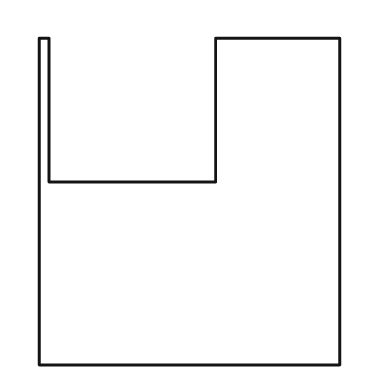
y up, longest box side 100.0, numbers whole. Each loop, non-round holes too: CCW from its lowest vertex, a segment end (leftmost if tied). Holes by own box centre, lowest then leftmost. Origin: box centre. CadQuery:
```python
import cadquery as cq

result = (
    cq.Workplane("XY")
    .moveTo(-46.0, -50.0)
    .lineTo(46.0, -50.0)
    .lineTo(46.0, 50.0)
    .lineTo(8.0, 50.0)
    .lineTo(8.0, 6.0)
    .lineTo(-43.0, 6.0)
    .lineTo(-43.0, 50.0)
    .lineTo(-46.0, 50.0)
    .close()
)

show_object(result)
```